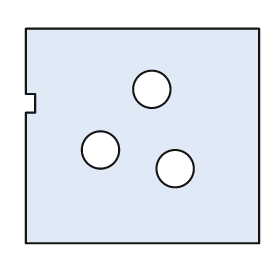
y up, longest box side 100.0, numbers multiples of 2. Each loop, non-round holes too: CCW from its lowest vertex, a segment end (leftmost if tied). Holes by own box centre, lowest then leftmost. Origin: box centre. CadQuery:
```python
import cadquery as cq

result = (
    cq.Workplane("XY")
    .moveTo(-50.0, -46.0)
    .lineTo(50.0, -46.0)
    .lineTo(50.0, 46.0)
    .lineTo(-50.0, 46.0)
    .lineTo(-50.0, 18.0)
    .lineTo(-46.0, 18.0)
    .lineTo(-46.0, 10.0)
    .lineTo(-50.0, 10.0)
    .close()
    .moveTo(14.0, -14.0)
    .circle(8.0)
    .moveTo(-18.0, -6.0)
    .circle(8.0)
    .moveTo(4.0, 20.0)
    .circle(8.0)
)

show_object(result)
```